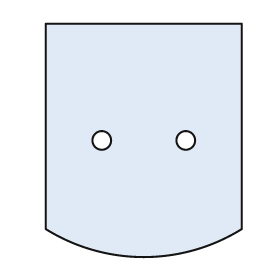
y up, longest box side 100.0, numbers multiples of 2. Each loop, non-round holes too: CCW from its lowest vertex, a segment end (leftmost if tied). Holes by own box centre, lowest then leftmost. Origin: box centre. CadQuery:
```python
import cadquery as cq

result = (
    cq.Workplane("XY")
    .moveTo(-42.0, -38.0)
    .threePointArc((0.0, -50.0), (42.0, -38.0))
    .lineTo(42.0, 50.0)
    .lineTo(-42.0, 50.0)
    .close()
    .moveTo(-18.0, 0.0)
    .circle(4.0)
    .moveTo(18.0, 0.0)
    .circle(4.0)
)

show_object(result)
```